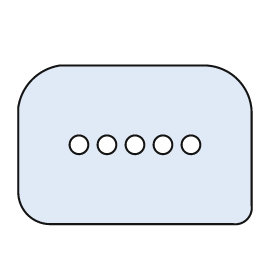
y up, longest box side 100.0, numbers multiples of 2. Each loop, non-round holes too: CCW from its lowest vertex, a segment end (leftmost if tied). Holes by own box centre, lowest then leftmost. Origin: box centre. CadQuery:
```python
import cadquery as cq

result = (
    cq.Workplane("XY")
    .moveTo(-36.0, -34.0)
    .lineTo(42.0, -34.0)
    .threePointArc((48.0, -32.0), (50.0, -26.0))
    .lineTo(50.0, 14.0)
    .threePointArc((44.0, 28.0), (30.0, 34.0))
    .lineTo(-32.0, 34.0)
    .threePointArc((-44.0, 28.0), (-50.0, 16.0))
    .lineTo(-50.0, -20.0)
    .threePointArc((-46.0, -30.0), (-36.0, -34.0))
    .close()
    .moveTo(-24.0, 0.0)
    .circle(4.0)
    .moveTo(-12.0, 0.0)
    .circle(4.0)
    .moveTo(0.0, 0.0)
    .circle(4.0)
    .moveTo(12.0, 0.0)
    .circle(4.0)
    .moveTo(24.0, 0.0)
    .circle(4.0)
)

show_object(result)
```